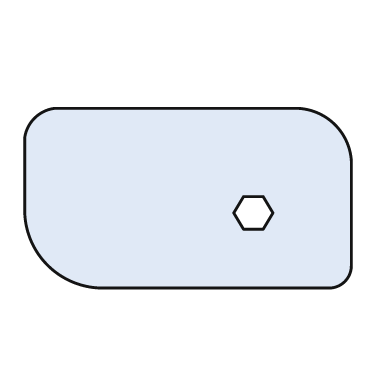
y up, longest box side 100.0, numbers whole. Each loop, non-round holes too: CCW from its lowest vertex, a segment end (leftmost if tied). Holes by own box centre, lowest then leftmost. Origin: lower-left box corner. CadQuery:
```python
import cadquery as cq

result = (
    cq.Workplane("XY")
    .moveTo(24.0, 0.0)
    .lineTo(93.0, 0.0)
    .threePointArc((98.0, 2.0), (100.0, 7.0))
    .lineTo(100.0, 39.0)
    .threePointArc((95.0, 50.0), (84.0, 55.0))
    .lineTo(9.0, 55.0)
    .threePointArc((3.0, 52.0), (0.0, 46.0))
    .lineTo(0.0, 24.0)
    .threePointArc((7.0, 7.0), (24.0, 0.0))
    .close()
    .moveTo(67.0, 18.0)
    .lineTo(73.0, 18.0)
    .lineTo(76.0, 23.0)
    .lineTo(73.0, 28.0)
    .lineTo(67.0, 28.0)
    .lineTo(64.0, 23.0)
    .close()
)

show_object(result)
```